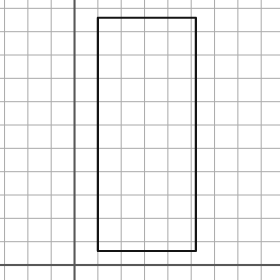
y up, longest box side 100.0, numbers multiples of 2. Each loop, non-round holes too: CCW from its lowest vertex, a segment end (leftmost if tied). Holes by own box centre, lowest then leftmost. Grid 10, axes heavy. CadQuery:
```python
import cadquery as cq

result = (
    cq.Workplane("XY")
    .moveTo(10.0, 6.0)
    .lineTo(52.0, 6.0)
    .lineTo(52.0, 106.0)
    .lineTo(10.0, 106.0)
    .close()
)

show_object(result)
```